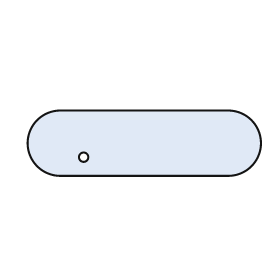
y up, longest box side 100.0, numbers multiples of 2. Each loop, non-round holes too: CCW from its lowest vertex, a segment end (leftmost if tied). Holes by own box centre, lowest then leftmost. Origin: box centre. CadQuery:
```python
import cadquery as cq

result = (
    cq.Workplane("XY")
    .moveTo(-36.0, -14.0)
    .lineTo(36.0, -14.0)
    .threePointArc((50.0, 0.0), (36.0, 14.0))
    .lineTo(-36.0, 14.0)
    .threePointArc((-50.0, 0.0), (-36.0, -14.0))
    .close()
    .moveTo(-26.0, -6.0)
    .circle(2.0)
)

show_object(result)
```